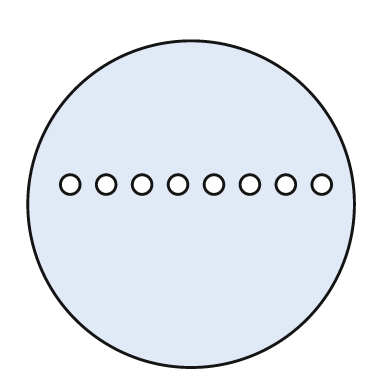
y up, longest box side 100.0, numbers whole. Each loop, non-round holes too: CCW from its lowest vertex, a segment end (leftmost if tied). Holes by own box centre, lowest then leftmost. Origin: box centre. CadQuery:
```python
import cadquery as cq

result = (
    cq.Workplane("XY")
    .moveTo(0.0, 0.0)
    .circle(50.0)
    .moveTo(-37.0, 6.0)
    .circle(3.0)
    .moveTo(-26.0, 6.0)
    .circle(3.0)
    .moveTo(-15.0, 6.0)
    .circle(3.0)
    .moveTo(-4.0, 6.0)
    .circle(3.0)
    .moveTo(7.0, 6.0)
    .circle(3.0)
    .moveTo(18.0, 6.0)
    .circle(3.0)
    .moveTo(29.0, 6.0)
    .circle(3.0)
    .moveTo(40.0, 6.0)
    .circle(3.0)
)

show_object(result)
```